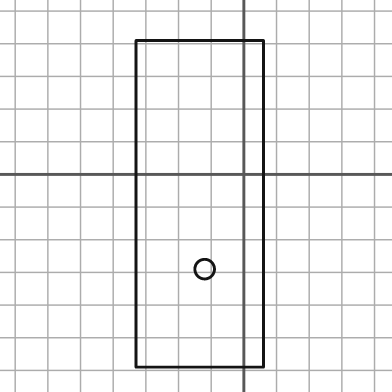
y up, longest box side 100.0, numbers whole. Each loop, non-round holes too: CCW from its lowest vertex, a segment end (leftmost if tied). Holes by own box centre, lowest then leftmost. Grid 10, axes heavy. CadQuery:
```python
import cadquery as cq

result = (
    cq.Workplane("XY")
    .moveTo(-33.0, -59.0)
    .lineTo(6.0, -59.0)
    .lineTo(6.0, 41.0)
    .lineTo(-33.0, 41.0)
    .close()
    .moveTo(-12.0, -29.0)
    .circle(3.0)
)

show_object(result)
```